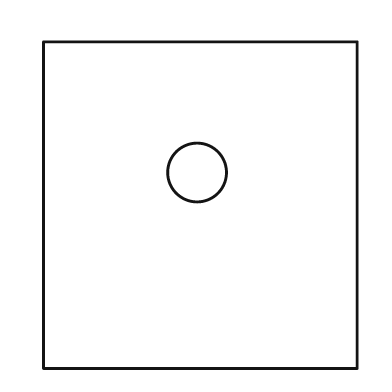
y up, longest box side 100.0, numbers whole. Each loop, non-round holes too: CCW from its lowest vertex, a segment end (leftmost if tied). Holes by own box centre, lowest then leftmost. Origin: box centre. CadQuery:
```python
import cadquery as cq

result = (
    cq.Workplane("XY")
    .moveTo(-48.0, -50.0)
    .lineTo(48.0, -50.0)
    .lineTo(48.0, 50.0)
    .lineTo(-48.0, 50.0)
    .close()
    .moveTo(-1.0, 10.0)
    .circle(9.0)
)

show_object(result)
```